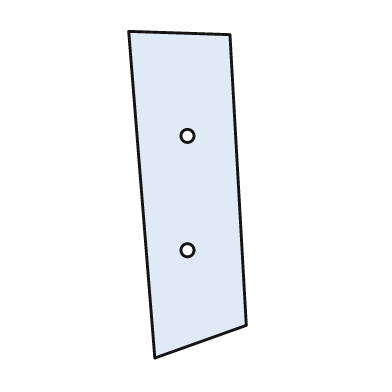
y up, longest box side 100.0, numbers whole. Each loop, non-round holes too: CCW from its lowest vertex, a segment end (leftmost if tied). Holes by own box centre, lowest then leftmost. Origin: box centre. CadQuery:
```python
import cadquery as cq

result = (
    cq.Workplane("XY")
    .moveTo(-10.0, -50.0)
    .lineTo(18.0, -40.0)
    .lineTo(13.0, 49.0)
    .lineTo(-18.0, 50.0)
    .close()
    .moveTo(0.0, -17.0)
    .circle(2.0)
    .moveTo(0.0, 18.0)
    .circle(2.0)
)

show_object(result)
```